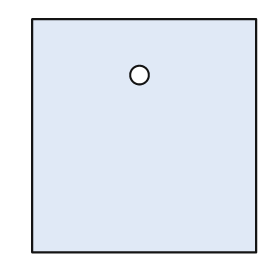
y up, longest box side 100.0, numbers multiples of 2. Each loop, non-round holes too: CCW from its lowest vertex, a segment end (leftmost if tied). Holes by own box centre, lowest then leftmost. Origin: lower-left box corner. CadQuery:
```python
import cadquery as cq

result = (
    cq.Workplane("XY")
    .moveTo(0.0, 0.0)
    .lineTo(96.0, 0.0)
    .lineTo(96.0, 100.0)
    .lineTo(0.0, 100.0)
    .close()
    .moveTo(46.0, 76.0)
    .circle(4.0)
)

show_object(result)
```